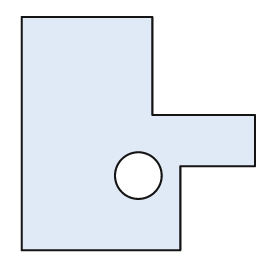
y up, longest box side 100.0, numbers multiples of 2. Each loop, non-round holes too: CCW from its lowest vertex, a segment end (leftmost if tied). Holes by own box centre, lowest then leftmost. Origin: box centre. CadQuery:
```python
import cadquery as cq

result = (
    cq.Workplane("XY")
    .moveTo(-50.0, -50.0)
    .lineTo(18.0, -50.0)
    .lineTo(18.0, -14.0)
    .lineTo(50.0, -14.0)
    .lineTo(50.0, 8.0)
    .lineTo(6.0, 8.0)
    .lineTo(6.0, 50.0)
    .lineTo(-50.0, 50.0)
    .close()
    .moveTo(0.0, -18.0)
    .circle(10.0)
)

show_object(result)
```